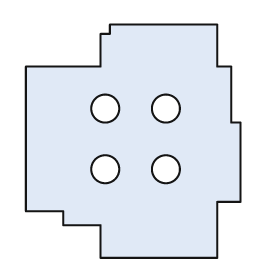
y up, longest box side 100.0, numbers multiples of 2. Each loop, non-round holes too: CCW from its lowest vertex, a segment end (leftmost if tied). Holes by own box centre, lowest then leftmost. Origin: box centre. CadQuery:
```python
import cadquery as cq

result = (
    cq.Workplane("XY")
    .moveTo(-14.0, -50.0)
    .lineTo(36.0, -50.0)
    .lineTo(36.0, -26.0)
    .lineTo(46.0, -26.0)
    .lineTo(46.0, 8.0)
    .lineTo(42.0, 8.0)
    .lineTo(42.0, 32.0)
    .lineTo(36.0, 32.0)
    .lineTo(36.0, 50.0)
    .lineTo(-10.0, 50.0)
    .lineTo(-10.0, 46.0)
    .lineTo(-14.0, 46.0)
    .lineTo(-14.0, 32.0)
    .lineTo(-46.0, 32.0)
    .lineTo(-46.0, -30.0)
    .lineTo(-30.0, -30.0)
    .lineTo(-30.0, -36.0)
    .lineTo(-14.0, -36.0)
    .close()
    .moveTo(-12.0, -12.0)
    .circle(6.0)
    .moveTo(14.0, -12.0)
    .circle(6.0)
    .moveTo(-12.0, 14.0)
    .circle(6.0)
    .moveTo(14.0, 14.0)
    .circle(6.0)
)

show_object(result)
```